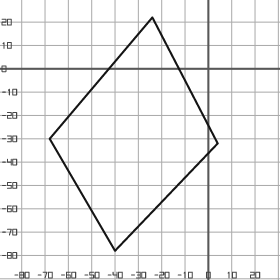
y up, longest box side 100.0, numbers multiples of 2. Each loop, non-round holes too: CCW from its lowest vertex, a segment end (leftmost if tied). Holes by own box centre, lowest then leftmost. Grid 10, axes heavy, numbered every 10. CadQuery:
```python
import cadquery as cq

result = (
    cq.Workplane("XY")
    .moveTo(-40.0, -78.0)
    .lineTo(4.0, -32.0)
    .lineTo(-24.0, 22.0)
    .lineTo(-68.0, -30.0)
    .close()
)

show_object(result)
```